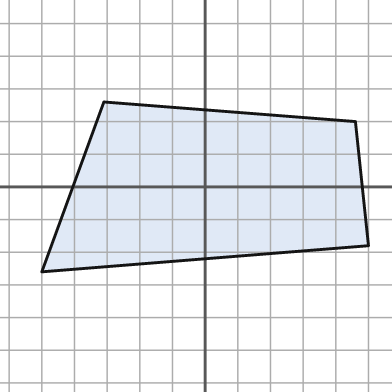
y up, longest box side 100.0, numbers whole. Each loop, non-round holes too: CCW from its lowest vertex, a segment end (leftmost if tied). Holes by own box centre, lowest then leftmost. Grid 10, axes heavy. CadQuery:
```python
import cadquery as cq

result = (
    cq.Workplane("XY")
    .moveTo(-50.0, -26.0)
    .lineTo(50.0, -18.0)
    .lineTo(46.0, 20.0)
    .lineTo(-31.0, 26.0)
    .close()
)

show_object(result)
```